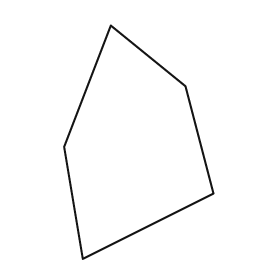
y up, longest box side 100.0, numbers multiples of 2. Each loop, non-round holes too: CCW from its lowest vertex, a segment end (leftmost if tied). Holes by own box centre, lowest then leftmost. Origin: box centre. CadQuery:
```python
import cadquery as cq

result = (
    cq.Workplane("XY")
    .moveTo(-24.0, -50.0)
    .lineTo(32.0, -22.0)
    .lineTo(20.0, 24.0)
    .lineTo(-12.0, 50.0)
    .lineTo(-32.0, -2.0)
    .close()
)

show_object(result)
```